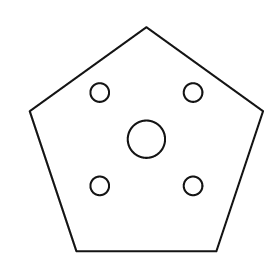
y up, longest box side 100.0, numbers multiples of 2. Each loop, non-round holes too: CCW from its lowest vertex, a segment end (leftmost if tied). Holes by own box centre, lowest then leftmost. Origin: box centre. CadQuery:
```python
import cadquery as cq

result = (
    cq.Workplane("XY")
    .moveTo(-30.0, -48.0)
    .lineTo(30.0, -48.0)
    .lineTo(50.0, 12.0)
    .lineTo(0.0, 48.0)
    .lineTo(-50.0, 12.0)
    .close()
    .moveTo(-20.0, -20.0)
    .circle(4.0)
    .moveTo(20.0, -20.0)
    .circle(4.0)
    .moveTo(0.0, 0.0)
    .circle(8.0)
    .moveTo(-20.0, 20.0)
    .circle(4.0)
    .moveTo(20.0, 20.0)
    .circle(4.0)
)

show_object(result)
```